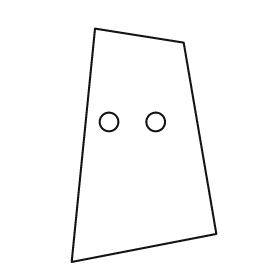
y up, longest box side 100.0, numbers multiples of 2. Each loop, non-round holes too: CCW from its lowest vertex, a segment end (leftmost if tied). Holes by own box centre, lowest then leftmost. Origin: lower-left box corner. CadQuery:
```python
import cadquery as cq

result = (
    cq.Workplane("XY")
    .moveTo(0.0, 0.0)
    .lineTo(62.0, 12.0)
    .lineTo(48.0, 94.0)
    .lineTo(10.0, 100.0)
    .close()
    .moveTo(16.0, 60.0)
    .circle(4.0)
    .moveTo(36.0, 60.0)
    .circle(4.0)
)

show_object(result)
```